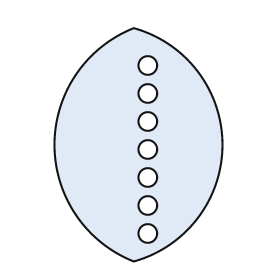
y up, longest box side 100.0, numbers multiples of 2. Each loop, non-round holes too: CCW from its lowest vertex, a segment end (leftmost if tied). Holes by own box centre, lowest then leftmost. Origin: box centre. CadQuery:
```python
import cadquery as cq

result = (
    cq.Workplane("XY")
    .moveTo(-2.0, -50.0)
    .threePointArc((36.0, 0.0), (-2.0, 50.0))
    .threePointArc((-36.0, 0.0), (-2.0, -50.0))
    .close()
    .moveTo(4.0, -38.0)
    .circle(4.0)
    .moveTo(4.0, -26.0)
    .circle(4.0)
    .moveTo(4.0, -14.0)
    .circle(4.0)
    .moveTo(4.0, -2.0)
    .circle(4.0)
    .moveTo(4.0, 10.0)
    .circle(4.0)
    .moveTo(4.0, 22.0)
    .circle(4.0)
    .moveTo(4.0, 34.0)
    .circle(4.0)
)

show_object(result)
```